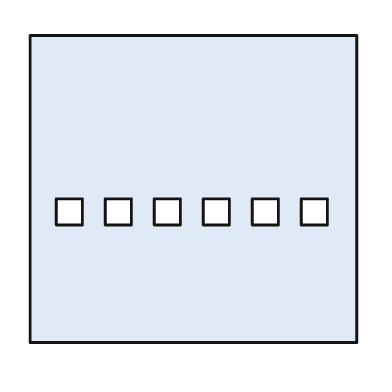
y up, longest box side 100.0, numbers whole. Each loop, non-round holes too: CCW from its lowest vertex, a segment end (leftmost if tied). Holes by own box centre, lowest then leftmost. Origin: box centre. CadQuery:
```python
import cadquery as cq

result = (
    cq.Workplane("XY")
    .moveTo(-50.0, -47.0)
    .lineTo(50.0, -47.0)
    .lineTo(50.0, 47.0)
    .lineTo(-50.0, 47.0)
    .close()
    .moveTo(-42.0, -11.0)
    .lineTo(-34.0, -11.0)
    .lineTo(-34.0, -3.0)
    .lineTo(-42.0, -3.0)
    .close()
    .moveTo(-27.0, -11.0)
    .lineTo(-19.0, -11.0)
    .lineTo(-19.0, -3.0)
    .lineTo(-27.0, -3.0)
    .close()
    .moveTo(-12.0, -11.0)
    .lineTo(-4.0, -11.0)
    .lineTo(-4.0, -3.0)
    .lineTo(-12.0, -3.0)
    .close()
    .moveTo(3.0, -11.0)
    .lineTo(11.0, -11.0)
    .lineTo(11.0, -3.0)
    .lineTo(3.0, -3.0)
    .close()
    .moveTo(18.0, -11.0)
    .lineTo(26.0, -11.0)
    .lineTo(26.0, -3.0)
    .lineTo(18.0, -3.0)
    .close()
    .moveTo(33.0, -11.0)
    .lineTo(41.0, -11.0)
    .lineTo(41.0, -3.0)
    .lineTo(33.0, -3.0)
    .close()
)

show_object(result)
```